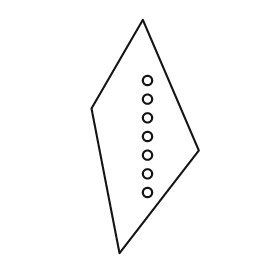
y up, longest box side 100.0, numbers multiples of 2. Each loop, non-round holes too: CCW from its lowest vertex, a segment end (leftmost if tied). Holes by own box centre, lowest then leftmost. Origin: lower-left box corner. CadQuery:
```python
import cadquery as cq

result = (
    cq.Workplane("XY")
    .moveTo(12.0, 0.0)
    .lineTo(46.0, 44.0)
    .lineTo(22.0, 100.0)
    .lineTo(0.0, 62.0)
    .close()
    .moveTo(24.0, 26.0)
    .circle(2.0)
    .moveTo(24.0, 34.0)
    .circle(2.0)
    .moveTo(24.0, 42.0)
    .circle(2.0)
    .moveTo(24.0, 50.0)
    .circle(2.0)
    .moveTo(24.0, 58.0)
    .circle(2.0)
    .moveTo(24.0, 66.0)
    .circle(2.0)
    .moveTo(24.0, 74.0)
    .circle(2.0)
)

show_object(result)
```